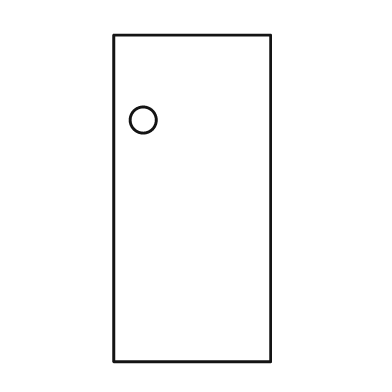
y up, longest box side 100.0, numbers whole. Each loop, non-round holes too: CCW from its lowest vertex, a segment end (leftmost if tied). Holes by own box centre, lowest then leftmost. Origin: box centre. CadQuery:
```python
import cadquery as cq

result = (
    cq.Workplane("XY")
    .moveTo(-24.0, -50.0)
    .lineTo(24.0, -50.0)
    .lineTo(24.0, 50.0)
    .lineTo(-24.0, 50.0)
    .close()
    .moveTo(-15.0, 24.0)
    .circle(4.0)
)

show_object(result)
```